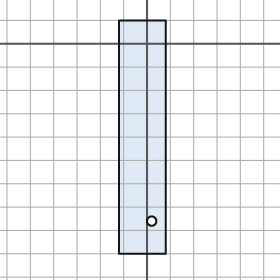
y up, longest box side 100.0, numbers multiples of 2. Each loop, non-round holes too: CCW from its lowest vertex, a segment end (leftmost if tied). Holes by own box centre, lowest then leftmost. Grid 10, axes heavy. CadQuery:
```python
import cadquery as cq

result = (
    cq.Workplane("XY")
    .moveTo(-12.0, -90.0)
    .lineTo(8.0, -90.0)
    .lineTo(8.0, 10.0)
    .lineTo(-12.0, 10.0)
    .close()
    .moveTo(2.0, -76.0)
    .circle(2.0)
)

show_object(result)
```